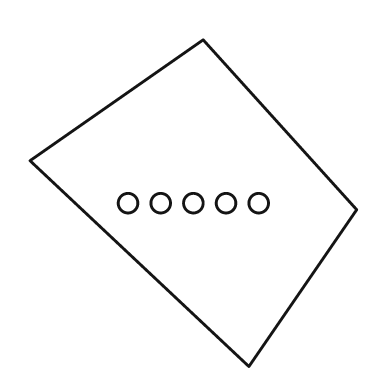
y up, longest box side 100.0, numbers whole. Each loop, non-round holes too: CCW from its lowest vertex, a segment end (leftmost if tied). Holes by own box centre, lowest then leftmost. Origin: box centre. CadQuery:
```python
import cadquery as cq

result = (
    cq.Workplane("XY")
    .moveTo(17.0, -50.0)
    .lineTo(50.0, -2.0)
    .lineTo(3.0, 50.0)
    .lineTo(-50.0, 13.0)
    .close()
    .moveTo(-20.0, 0.0)
    .circle(3.0)
    .moveTo(-10.0, 0.0)
    .circle(3.0)
    .moveTo(0.0, 0.0)
    .circle(3.0)
    .moveTo(10.0, 0.0)
    .circle(3.0)
    .moveTo(20.0, 0.0)
    .circle(3.0)
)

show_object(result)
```